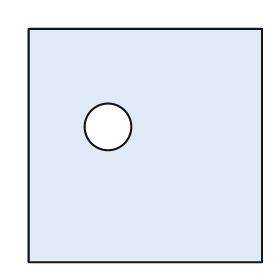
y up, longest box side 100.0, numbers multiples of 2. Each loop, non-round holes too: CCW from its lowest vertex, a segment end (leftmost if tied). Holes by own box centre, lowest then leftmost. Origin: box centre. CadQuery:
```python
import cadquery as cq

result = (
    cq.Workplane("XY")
    .moveTo(-50.0, -50.0)
    .lineTo(50.0, -50.0)
    .lineTo(50.0, 50.0)
    .lineTo(-50.0, 50.0)
    .close()
    .moveTo(-16.0, 8.0)
    .circle(10.0)
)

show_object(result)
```